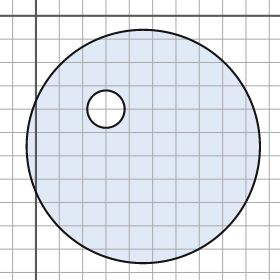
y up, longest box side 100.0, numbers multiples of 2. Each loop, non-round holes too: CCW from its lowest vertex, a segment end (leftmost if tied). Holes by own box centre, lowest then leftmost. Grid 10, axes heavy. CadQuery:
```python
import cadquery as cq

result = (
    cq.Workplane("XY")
    .moveTo(46.0, -56.0)
    .circle(50.0)
    .moveTo(30.0, -40.0)
    .circle(8.0)
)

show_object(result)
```